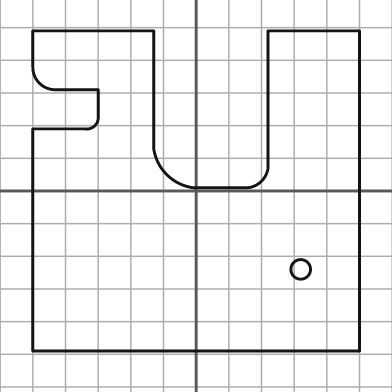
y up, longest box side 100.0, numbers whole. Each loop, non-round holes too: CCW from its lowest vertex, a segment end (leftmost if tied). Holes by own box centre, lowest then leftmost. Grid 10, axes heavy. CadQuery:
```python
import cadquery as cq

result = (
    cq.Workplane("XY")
    .moveTo(-50.0, -49.0)
    .lineTo(50.0, -49.0)
    .lineTo(50.0, 49.0)
    .lineTo(22.0, 49.0)
    .lineTo(22.0, 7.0)
    .threePointArc((20.0, 3.0), (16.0, 1.0))
    .lineTo(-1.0, 1.0)
    .threePointArc((-9.0, 5.0), (-13.0, 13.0))
    .lineTo(-13.0, 49.0)
    .lineTo(-50.0, 49.0)
    .lineTo(-50.0, 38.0)
    .threePointArc((-48.0, 33.0), (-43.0, 31.0))
    .lineTo(-30.0, 31.0)
    .lineTo(-30.0, 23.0)
    .threePointArc((-31.0, 20.0), (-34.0, 19.0))
    .lineTo(-50.0, 19.0)
    .close()
    .moveTo(32.0, -24.0)
    .circle(3.0)
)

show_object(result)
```